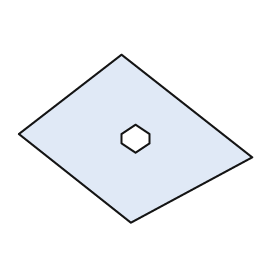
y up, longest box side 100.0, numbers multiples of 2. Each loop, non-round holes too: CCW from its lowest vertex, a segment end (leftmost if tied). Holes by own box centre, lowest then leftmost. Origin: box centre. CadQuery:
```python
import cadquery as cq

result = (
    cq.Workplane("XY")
    .moveTo(-2.0, -36.0)
    .lineTo(50.0, -8.0)
    .lineTo(-6.0, 36.0)
    .lineTo(-50.0, 2.0)
    .close()
    .moveTo(0.0, -6.0)
    .lineTo(6.0, -2.0)
    .lineTo(6.0, 2.0)
    .lineTo(0.0, 6.0)
    .lineTo(-6.0, 2.0)
    .lineTo(-6.0, -2.0)
    .close()
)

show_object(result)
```